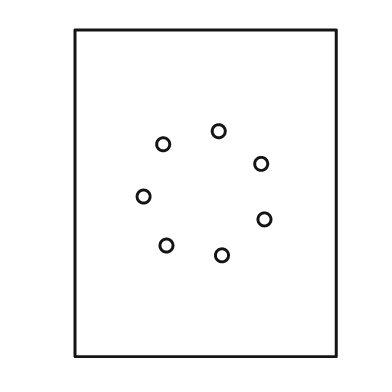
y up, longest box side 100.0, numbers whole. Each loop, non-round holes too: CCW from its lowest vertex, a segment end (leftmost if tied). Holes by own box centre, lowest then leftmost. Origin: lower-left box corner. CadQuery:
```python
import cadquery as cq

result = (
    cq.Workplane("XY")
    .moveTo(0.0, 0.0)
    .lineTo(80.0, 0.0)
    .lineTo(80.0, 100.0)
    .lineTo(0.0, 100.0)
    .close()
    .moveTo(45.0, 31.0)
    .circle(2.0)
    .moveTo(28.0, 34.0)
    .circle(2.0)
    .moveTo(58.0, 42.0)
    .circle(2.0)
    .moveTo(21.0, 49.0)
    .circle(2.0)
    .moveTo(57.0, 59.0)
    .circle(2.0)
    .moveTo(27.0, 65.0)
    .circle(2.0)
    .moveTo(44.0, 69.0)
    .circle(2.0)
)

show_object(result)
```